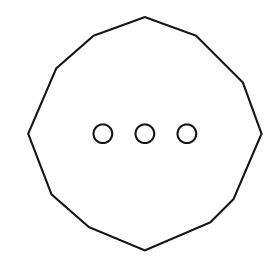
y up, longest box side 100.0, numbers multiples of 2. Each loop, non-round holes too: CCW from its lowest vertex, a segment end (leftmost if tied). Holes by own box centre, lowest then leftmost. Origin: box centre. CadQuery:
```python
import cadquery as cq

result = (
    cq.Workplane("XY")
    .moveTo(0.0, -50.0)
    .lineTo(28.0, -38.0)
    .lineTo(38.0, -28.0)
    .lineTo(50.0, 0.0)
    .lineTo(42.0, 22.0)
    .lineTo(22.0, 42.0)
    .lineTo(0.0, 50.0)
    .lineTo(-22.0, 42.0)
    .lineTo(-38.0, 28.0)
    .lineTo(-50.0, 0.0)
    .lineTo(-40.0, -26.0)
    .lineTo(-24.0, -40.0)
    .close()
    .moveTo(-18.0, 0.0)
    .circle(4.0)
    .moveTo(0.0, 0.0)
    .circle(4.0)
    .moveTo(18.0, 0.0)
    .circle(4.0)
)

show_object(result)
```